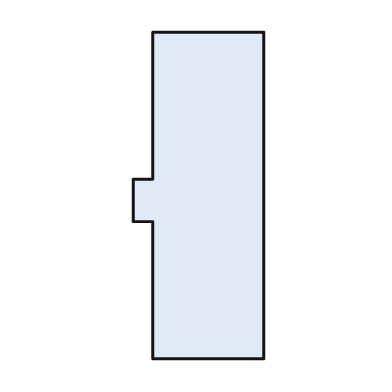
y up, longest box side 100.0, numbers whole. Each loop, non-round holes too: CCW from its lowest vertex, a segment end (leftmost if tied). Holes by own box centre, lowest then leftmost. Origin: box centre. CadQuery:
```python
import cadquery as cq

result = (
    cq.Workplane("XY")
    .moveTo(-14.0, -50.0)
    .lineTo(20.0, -50.0)
    .lineTo(20.0, 50.0)
    .lineTo(-14.0, 50.0)
    .lineTo(-14.0, 5.0)
    .lineTo(-20.0, 5.0)
    .lineTo(-20.0, -8.0)
    .lineTo(-14.0, -8.0)
    .close()
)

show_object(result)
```